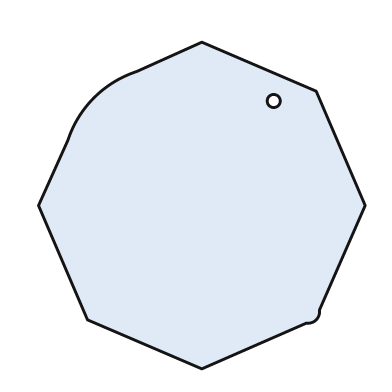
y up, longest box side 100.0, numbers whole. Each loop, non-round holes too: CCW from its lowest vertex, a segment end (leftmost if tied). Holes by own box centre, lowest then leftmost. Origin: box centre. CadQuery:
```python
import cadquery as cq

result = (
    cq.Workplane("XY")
    .moveTo(0.0, -50.0)
    .lineTo(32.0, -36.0)
    .threePointArc((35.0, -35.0), (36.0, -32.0))
    .lineTo(50.0, 0.0)
    .lineTo(35.0, 35.0)
    .lineTo(0.0, 50.0)
    .lineTo(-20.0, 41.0)
    .threePointArc((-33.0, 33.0), (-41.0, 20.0))
    .lineTo(-50.0, 0.0)
    .lineTo(-35.0, -35.0)
    .close()
    .moveTo(22.0, 32.0)
    .circle(2.0)
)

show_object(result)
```